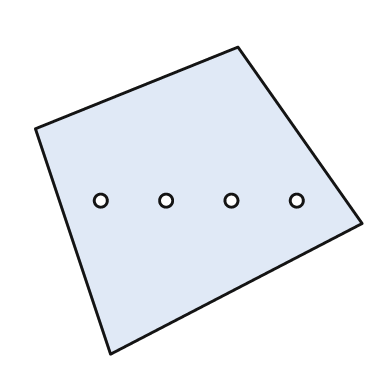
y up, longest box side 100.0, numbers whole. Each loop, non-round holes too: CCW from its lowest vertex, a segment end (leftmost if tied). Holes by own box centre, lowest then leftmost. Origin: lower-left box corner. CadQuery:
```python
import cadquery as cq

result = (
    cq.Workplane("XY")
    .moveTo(23.0, 0.0)
    .lineTo(100.0, 40.0)
    .lineTo(62.0, 94.0)
    .lineTo(0.0, 69.0)
    .close()
    .moveTo(20.0, 47.0)
    .circle(2.0)
    .moveTo(40.0, 47.0)
    .circle(2.0)
    .moveTo(60.0, 47.0)
    .circle(2.0)
    .moveTo(80.0, 47.0)
    .circle(2.0)
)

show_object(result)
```